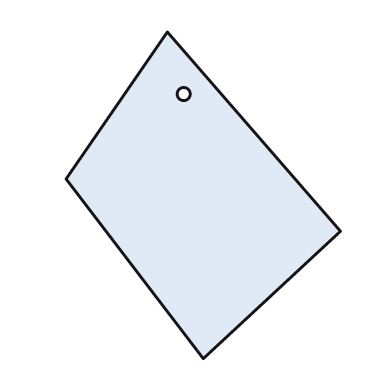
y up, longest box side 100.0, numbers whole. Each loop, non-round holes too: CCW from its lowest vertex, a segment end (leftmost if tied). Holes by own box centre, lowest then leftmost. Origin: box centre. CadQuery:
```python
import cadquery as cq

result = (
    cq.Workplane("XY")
    .moveTo(0.0, -50.0)
    .lineTo(42.0, -11.0)
    .lineTo(-11.0, 50.0)
    .lineTo(-42.0, 5.0)
    .close()
    .moveTo(-6.0, 31.0)
    .circle(2.0)
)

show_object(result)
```